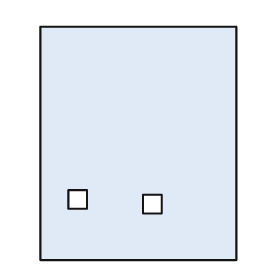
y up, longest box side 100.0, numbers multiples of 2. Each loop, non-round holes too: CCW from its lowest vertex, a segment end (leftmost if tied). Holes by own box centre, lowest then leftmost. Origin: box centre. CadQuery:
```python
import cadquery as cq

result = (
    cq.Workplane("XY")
    .moveTo(-42.0, -50.0)
    .lineTo(42.0, -50.0)
    .lineTo(42.0, 50.0)
    .lineTo(-42.0, 50.0)
    .close()
    .moveTo(2.0, -30.0)
    .lineTo(10.0, -30.0)
    .lineTo(10.0, -22.0)
    .lineTo(2.0, -22.0)
    .close()
    .moveTo(-30.0, -28.0)
    .lineTo(-22.0, -28.0)
    .lineTo(-22.0, -20.0)
    .lineTo(-30.0, -20.0)
    .close()
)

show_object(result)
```